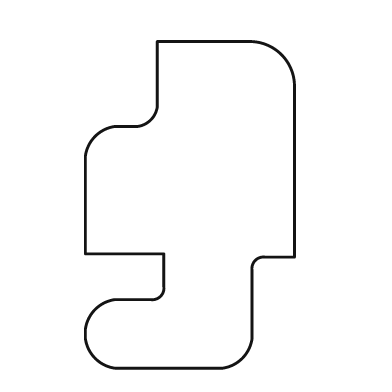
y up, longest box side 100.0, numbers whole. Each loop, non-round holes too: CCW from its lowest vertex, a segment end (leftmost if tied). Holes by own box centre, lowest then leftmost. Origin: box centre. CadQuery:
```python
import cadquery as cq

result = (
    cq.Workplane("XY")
    .moveTo(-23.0, -50.0)
    .lineTo(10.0, -50.0)
    .threePointArc((16.0, -47.0), (19.0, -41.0))
    .lineTo(19.0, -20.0)
    .threePointArc((20.0, -17.0), (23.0, -16.0))
    .lineTo(32.0, -16.0)
    .lineTo(32.0, 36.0)
    .threePointArc((28.0, 46.0), (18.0, 50.0))
    .lineTo(-10.0, 50.0)
    .lineTo(-10.0, 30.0)
    .threePointArc((-12.0, 26.0), (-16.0, 24.0))
    .lineTo(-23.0, 24.0)
    .threePointArc((-29.0, 21.0), (-32.0, 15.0))
    .lineTo(-32.0, -15.0)
    .lineTo(-8.0, -15.0)
    .lineTo(-8.0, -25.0)
    .threePointArc((-9.0, -28.0), (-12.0, -29.0))
    .lineTo(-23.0, -29.0)
    .threePointArc((-29.0, -32.0), (-32.0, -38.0))
    .lineTo(-32.0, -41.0)
    .threePointArc((-29.0, -47.0), (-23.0, -50.0))
    .close()
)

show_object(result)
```